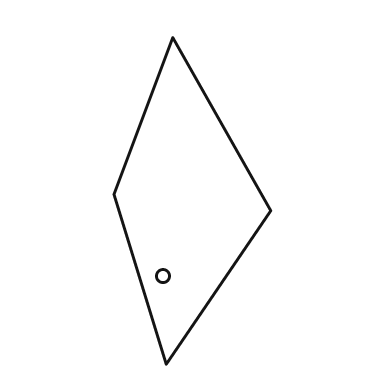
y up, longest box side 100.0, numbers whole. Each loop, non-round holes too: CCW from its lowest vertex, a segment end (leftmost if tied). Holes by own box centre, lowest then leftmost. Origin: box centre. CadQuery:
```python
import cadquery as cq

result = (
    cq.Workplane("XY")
    .moveTo(-8.0, -50.0)
    .lineTo(24.0, -3.0)
    .lineTo(-6.0, 50.0)
    .lineTo(-24.0, 2.0)
    .close()
    .moveTo(-9.0, -23.0)
    .circle(2.0)
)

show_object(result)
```